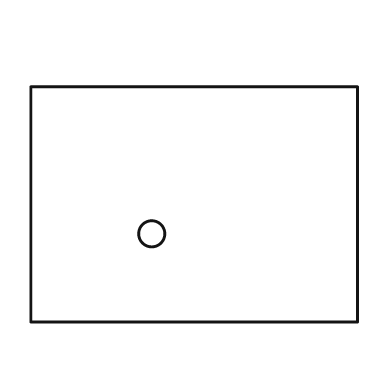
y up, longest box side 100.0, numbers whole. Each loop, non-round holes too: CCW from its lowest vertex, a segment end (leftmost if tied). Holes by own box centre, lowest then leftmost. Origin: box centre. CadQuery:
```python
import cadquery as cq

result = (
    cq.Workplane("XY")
    .moveTo(-50.0, -36.0)
    .lineTo(50.0, -36.0)
    .lineTo(50.0, 36.0)
    .lineTo(-50.0, 36.0)
    .close()
    .moveTo(-13.0, -9.0)
    .circle(4.0)
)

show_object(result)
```